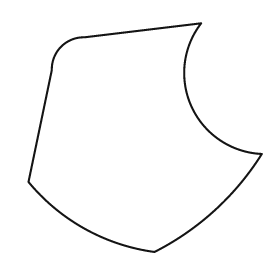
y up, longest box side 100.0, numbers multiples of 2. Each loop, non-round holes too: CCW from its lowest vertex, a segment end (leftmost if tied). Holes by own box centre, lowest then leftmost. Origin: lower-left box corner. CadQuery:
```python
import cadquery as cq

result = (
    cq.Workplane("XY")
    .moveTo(54.0, 0.0)
    .threePointArc((80.0, 18.0), (100.0, 42.0))
    .threePointArc((70.0, 62.0), (74.0, 98.0))
    .lineTo(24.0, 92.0)
    .threePointArc((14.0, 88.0), (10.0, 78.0))
    .lineTo(0.0, 30.0)
    .threePointArc((24.0, 10.0), (54.0, 0.0))
    .close()
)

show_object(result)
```